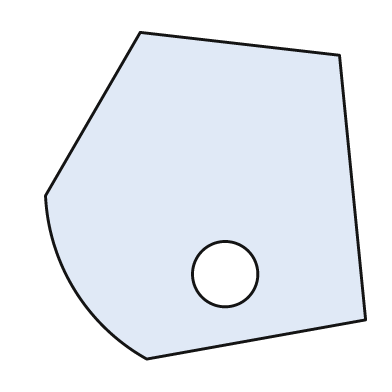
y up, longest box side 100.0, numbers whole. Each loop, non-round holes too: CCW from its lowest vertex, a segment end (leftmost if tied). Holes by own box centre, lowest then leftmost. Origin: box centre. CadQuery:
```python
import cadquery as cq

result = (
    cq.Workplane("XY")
    .moveTo(-18.0, -50.0)
    .lineTo(49.0, -38.0)
    .lineTo(41.0, 43.0)
    .lineTo(-20.0, 50.0)
    .lineTo(-49.0, 0.0)
    .threePointArc((-40.0, -29.0), (-18.0, -50.0))
    .close()
    .moveTo(6.0, -24.0)
    .circle(10.0)
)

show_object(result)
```